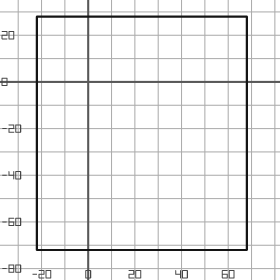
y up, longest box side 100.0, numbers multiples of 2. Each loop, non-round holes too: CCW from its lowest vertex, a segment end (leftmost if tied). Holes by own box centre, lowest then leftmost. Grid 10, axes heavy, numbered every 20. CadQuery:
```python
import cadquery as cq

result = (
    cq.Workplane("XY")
    .moveTo(-22.0, -72.0)
    .lineTo(68.0, -72.0)
    .lineTo(68.0, 28.0)
    .lineTo(-22.0, 28.0)
    .close()
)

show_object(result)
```